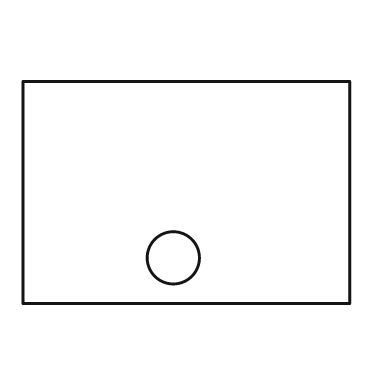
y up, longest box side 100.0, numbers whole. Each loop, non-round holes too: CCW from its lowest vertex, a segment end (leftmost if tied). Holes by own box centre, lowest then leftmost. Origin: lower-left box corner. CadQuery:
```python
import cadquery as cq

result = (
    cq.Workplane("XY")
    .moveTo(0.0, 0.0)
    .lineTo(100.0, 0.0)
    .lineTo(100.0, 68.0)
    .lineTo(0.0, 68.0)
    .close()
    .moveTo(46.0, 14.0)
    .circle(8.0)
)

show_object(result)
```